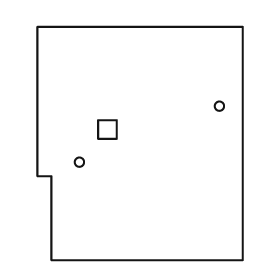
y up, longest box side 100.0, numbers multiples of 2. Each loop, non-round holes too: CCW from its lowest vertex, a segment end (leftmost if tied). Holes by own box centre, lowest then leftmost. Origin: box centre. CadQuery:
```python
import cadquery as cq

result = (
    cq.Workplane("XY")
    .moveTo(-38.0, -50.0)
    .lineTo(44.0, -50.0)
    .lineTo(44.0, 50.0)
    .lineTo(-44.0, 50.0)
    .lineTo(-44.0, -14.0)
    .lineTo(-38.0, -14.0)
    .close()
    .moveTo(-26.0, -8.0)
    .circle(2.0)
    .moveTo(-18.0, 2.0)
    .lineTo(-10.0, 2.0)
    .lineTo(-10.0, 10.0)
    .lineTo(-18.0, 10.0)
    .close()
    .moveTo(34.0, 16.0)
    .circle(2.0)
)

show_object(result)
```